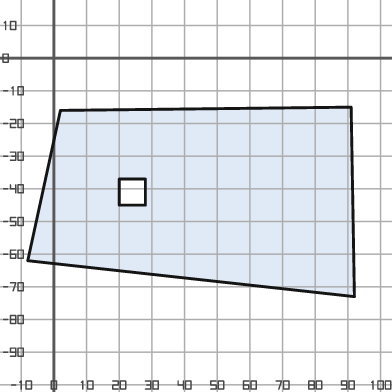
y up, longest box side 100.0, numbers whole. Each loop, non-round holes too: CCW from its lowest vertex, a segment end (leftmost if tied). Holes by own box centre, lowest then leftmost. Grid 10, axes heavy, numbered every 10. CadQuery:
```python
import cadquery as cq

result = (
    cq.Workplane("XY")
    .moveTo(92.0, -73.0)
    .lineTo(91.0, -15.0)
    .lineTo(2.0, -16.0)
    .lineTo(-8.0, -62.0)
    .close()
    .moveTo(20.0, -45.0)
    .lineTo(28.0, -45.0)
    .lineTo(28.0, -37.0)
    .lineTo(20.0, -37.0)
    .close()
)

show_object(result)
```